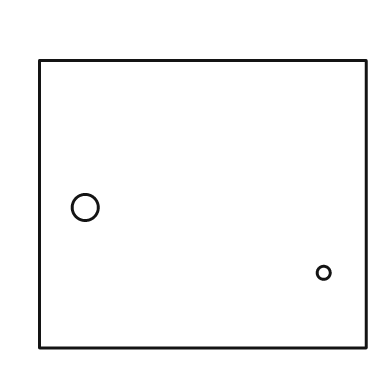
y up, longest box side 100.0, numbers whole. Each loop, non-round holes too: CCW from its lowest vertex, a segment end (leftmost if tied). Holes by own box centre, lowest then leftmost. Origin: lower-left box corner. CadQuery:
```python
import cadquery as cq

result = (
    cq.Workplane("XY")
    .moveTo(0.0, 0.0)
    .lineTo(100.0, 0.0)
    .lineTo(100.0, 88.0)
    .lineTo(0.0, 88.0)
    .close()
    .moveTo(87.0, 23.0)
    .circle(2.0)
    .moveTo(14.0, 43.0)
    .circle(4.0)
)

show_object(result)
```